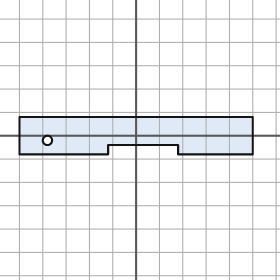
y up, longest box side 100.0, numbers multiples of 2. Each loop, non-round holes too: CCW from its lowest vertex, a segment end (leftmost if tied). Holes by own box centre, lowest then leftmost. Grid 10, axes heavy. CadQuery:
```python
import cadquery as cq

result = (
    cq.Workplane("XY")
    .moveTo(-50.0, -8.0)
    .lineTo(-12.0, -8.0)
    .lineTo(-12.0, -4.0)
    .lineTo(18.0, -4.0)
    .lineTo(18.0, -8.0)
    .lineTo(50.0, -8.0)
    .lineTo(50.0, 8.0)
    .lineTo(-50.0, 8.0)
    .close()
    .moveTo(-38.0, -2.0)
    .circle(2.0)
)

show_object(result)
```